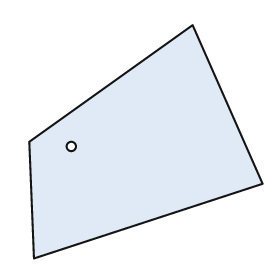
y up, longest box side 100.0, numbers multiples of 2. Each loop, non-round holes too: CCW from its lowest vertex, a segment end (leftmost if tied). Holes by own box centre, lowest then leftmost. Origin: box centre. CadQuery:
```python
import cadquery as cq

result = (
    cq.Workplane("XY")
    .moveTo(-48.0, -50.0)
    .lineTo(50.0, -18.0)
    .lineTo(20.0, 50.0)
    .lineTo(-50.0, 0.0)
    .close()
    .moveTo(-32.0, -2.0)
    .circle(2.0)
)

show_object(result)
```